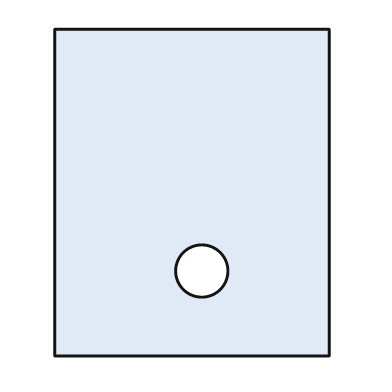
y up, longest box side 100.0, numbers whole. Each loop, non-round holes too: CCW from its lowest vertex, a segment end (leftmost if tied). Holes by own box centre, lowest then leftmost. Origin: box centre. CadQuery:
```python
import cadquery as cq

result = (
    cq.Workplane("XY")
    .moveTo(-42.0, -50.0)
    .lineTo(42.0, -50.0)
    .lineTo(42.0, 50.0)
    .lineTo(-42.0, 50.0)
    .close()
    .moveTo(3.0, -24.0)
    .circle(8.0)
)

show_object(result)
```